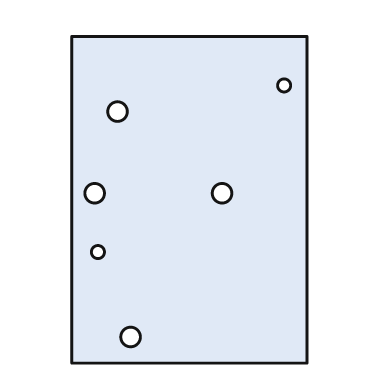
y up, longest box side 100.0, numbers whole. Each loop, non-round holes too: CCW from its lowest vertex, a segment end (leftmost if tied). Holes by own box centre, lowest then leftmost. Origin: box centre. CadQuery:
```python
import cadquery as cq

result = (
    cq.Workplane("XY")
    .moveTo(-36.0, -50.0)
    .lineTo(36.0, -50.0)
    .lineTo(36.0, 50.0)
    .lineTo(-36.0, 50.0)
    .close()
    .moveTo(-18.0, -42.0)
    .circle(3.0)
    .moveTo(-28.0, -16.0)
    .circle(2.0)
    .moveTo(-29.0, 2.0)
    .circle(3.0)
    .moveTo(10.0, 2.0)
    .circle(3.0)
    .moveTo(-22.0, 27.0)
    .circle(3.0)
    .moveTo(29.0, 35.0)
    .circle(2.0)
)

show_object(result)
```